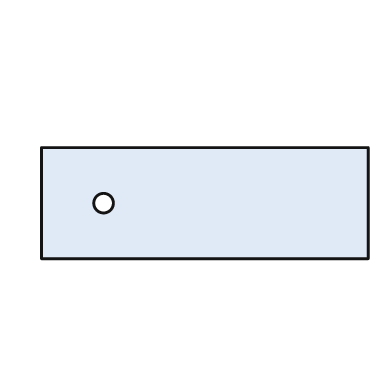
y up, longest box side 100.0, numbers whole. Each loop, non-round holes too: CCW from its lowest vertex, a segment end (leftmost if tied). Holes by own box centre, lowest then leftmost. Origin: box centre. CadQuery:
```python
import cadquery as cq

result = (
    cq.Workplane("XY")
    .moveTo(-50.0, -17.0)
    .lineTo(50.0, -17.0)
    .lineTo(50.0, 17.0)
    .lineTo(-50.0, 17.0)
    .close()
    .moveTo(-31.0, 0.0)
    .circle(3.0)
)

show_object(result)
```